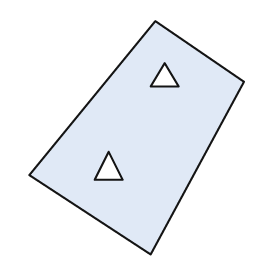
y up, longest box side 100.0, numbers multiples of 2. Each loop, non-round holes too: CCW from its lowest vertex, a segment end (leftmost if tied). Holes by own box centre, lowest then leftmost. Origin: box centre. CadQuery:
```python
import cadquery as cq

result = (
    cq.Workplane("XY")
    .moveTo(6.0, -50.0)
    .lineTo(46.0, 24.0)
    .lineTo(8.0, 50.0)
    .lineTo(-46.0, -16.0)
    .close()
    .moveTo(-18.0, -18.0)
    .lineTo(-6.0, -18.0)
    .lineTo(-12.0, -6.0)
    .close()
    .moveTo(6.0, 22.0)
    .lineTo(18.0, 22.0)
    .lineTo(12.0, 32.0)
    .close()
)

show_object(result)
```